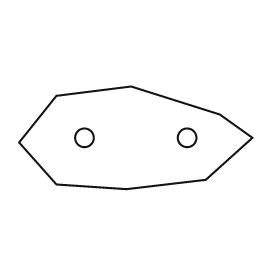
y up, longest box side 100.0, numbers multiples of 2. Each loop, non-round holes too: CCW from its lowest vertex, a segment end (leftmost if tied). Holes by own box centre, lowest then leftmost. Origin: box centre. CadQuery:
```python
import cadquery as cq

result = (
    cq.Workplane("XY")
    .moveTo(-4.0, -22.0)
    .lineTo(30.0, -18.0)
    .lineTo(50.0, 0.0)
    .lineTo(36.0, 10.0)
    .lineTo(-2.0, 22.0)
    .lineTo(-34.0, 18.0)
    .lineTo(-50.0, -2.0)
    .lineTo(-34.0, -20.0)
    .close()
    .moveTo(-22.0, 0.0)
    .circle(4.0)
    .moveTo(22.0, 0.0)
    .circle(4.0)
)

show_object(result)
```